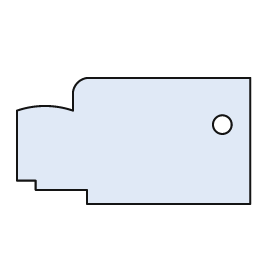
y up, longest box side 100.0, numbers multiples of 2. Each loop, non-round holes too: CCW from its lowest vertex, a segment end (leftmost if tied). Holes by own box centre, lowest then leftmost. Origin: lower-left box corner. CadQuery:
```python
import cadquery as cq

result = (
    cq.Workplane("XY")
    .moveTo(30.0, 0.0)
    .lineTo(100.0, 0.0)
    .lineTo(100.0, 54.0)
    .lineTo(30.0, 54.0)
    .threePointArc((26.0, 52.0), (24.0, 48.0))
    .lineTo(24.0, 40.0)
    .threePointArc((12.0, 42.0), (0.0, 40.0))
    .lineTo(0.0, 10.0)
    .lineTo(8.0, 10.0)
    .lineTo(8.0, 6.0)
    .lineTo(30.0, 6.0)
    .close()
    .moveTo(88.0, 34.0)
    .circle(4.0)
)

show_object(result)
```